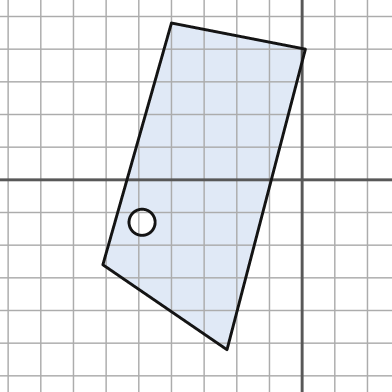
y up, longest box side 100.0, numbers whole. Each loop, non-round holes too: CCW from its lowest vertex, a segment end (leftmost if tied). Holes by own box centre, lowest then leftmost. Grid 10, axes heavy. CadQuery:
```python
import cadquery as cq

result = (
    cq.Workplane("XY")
    .moveTo(-23.0, -52.0)
    .lineTo(1.0, 40.0)
    .lineTo(-40.0, 48.0)
    .lineTo(-61.0, -26.0)
    .close()
    .moveTo(-49.0, -13.0)
    .circle(4.0)
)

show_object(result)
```